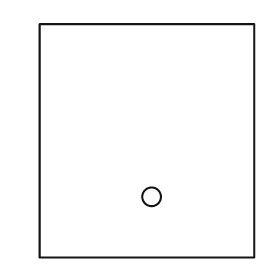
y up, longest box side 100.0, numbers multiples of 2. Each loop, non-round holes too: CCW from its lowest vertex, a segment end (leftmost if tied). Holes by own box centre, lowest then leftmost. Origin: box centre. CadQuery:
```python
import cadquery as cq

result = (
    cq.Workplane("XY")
    .moveTo(-46.0, -50.0)
    .lineTo(46.0, -50.0)
    .lineTo(46.0, 50.0)
    .lineTo(-46.0, 50.0)
    .close()
    .moveTo(2.0, -24.0)
    .circle(4.0)
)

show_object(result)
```